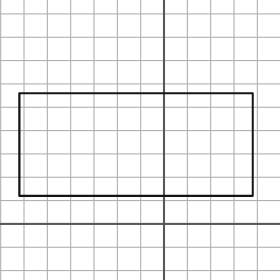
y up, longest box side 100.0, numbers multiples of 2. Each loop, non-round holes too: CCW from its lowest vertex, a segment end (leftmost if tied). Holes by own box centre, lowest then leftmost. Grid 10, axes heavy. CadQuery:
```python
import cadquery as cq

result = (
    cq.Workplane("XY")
    .moveTo(-62.0, 12.0)
    .lineTo(38.0, 12.0)
    .lineTo(38.0, 56.0)
    .lineTo(-62.0, 56.0)
    .close()
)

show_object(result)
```